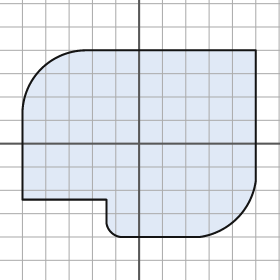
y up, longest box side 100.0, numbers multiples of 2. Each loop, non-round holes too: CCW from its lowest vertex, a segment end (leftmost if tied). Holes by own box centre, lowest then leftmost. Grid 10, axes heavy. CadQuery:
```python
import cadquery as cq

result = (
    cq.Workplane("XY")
    .moveTo(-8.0, -40.0)
    .lineTo(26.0, -40.0)
    .threePointArc((42.0, -32.0), (50.0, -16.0))
    .lineTo(50.0, 40.0)
    .lineTo(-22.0, 40.0)
    .threePointArc((-42.0, 32.0), (-50.0, 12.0))
    .lineTo(-50.0, -24.0)
    .lineTo(-14.0, -24.0)
    .lineTo(-14.0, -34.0)
    .threePointArc((-12.0, -38.0), (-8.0, -40.0))
    .close()
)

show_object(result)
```